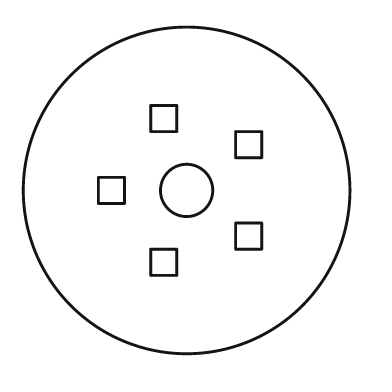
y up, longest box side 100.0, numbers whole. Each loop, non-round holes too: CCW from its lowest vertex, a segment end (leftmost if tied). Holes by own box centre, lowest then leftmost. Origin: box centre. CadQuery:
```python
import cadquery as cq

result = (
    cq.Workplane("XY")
    .moveTo(0.0, 0.0)
    .circle(50.0)
    .moveTo(-11.0, -26.0)
    .lineTo(-3.0, -26.0)
    .lineTo(-3.0, -18.0)
    .lineTo(-11.0, -18.0)
    .close()
    .moveTo(15.0, -18.0)
    .lineTo(23.0, -18.0)
    .lineTo(23.0, -10.0)
    .lineTo(15.0, -10.0)
    .close()
    .moveTo(-27.0, -4.0)
    .lineTo(-19.0, -4.0)
    .lineTo(-19.0, 4.0)
    .lineTo(-27.0, 4.0)
    .close()
    .moveTo(0.0, 0.0)
    .circle(8.0)
    .moveTo(15.0, 10.0)
    .lineTo(23.0, 10.0)
    .lineTo(23.0, 18.0)
    .lineTo(15.0, 18.0)
    .close()
    .moveTo(-11.0, 18.0)
    .lineTo(-3.0, 18.0)
    .lineTo(-3.0, 26.0)
    .lineTo(-11.0, 26.0)
    .close()
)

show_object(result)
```